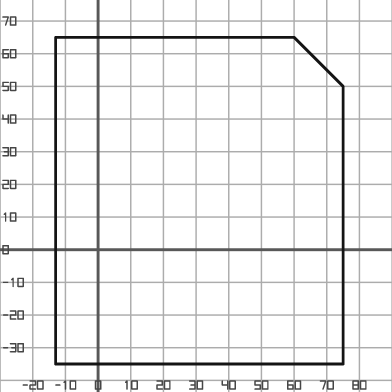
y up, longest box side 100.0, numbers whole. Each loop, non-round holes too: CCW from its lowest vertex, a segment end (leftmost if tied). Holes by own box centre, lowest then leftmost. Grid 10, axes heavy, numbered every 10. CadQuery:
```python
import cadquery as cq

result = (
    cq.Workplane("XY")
    .moveTo(-13.0, -35.0)
    .lineTo(75.0, -35.0)
    .lineTo(75.0, 50.0)
    .lineTo(60.0, 65.0)
    .lineTo(-13.0, 65.0)
    .close()
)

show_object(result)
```